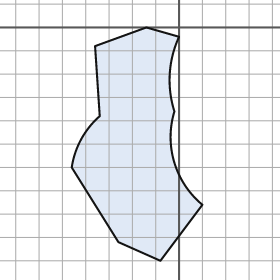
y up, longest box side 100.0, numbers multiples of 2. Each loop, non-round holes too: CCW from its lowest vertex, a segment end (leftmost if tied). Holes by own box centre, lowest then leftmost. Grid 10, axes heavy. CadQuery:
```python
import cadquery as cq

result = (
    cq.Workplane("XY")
    .moveTo(-8.0, -100.0)
    .lineTo(10.0, -76.0)
    .threePointArc((-2.0, -58.0), (-2.0, -36.0))
    .threePointArc((-4.0, -20.0), (0.0, -4.0))
    .lineTo(-14.0, 0.0)
    .lineTo(-36.0, -8.0)
    .lineTo(-34.0, -38.0)
    .threePointArc((-42.0, -48.0), (-46.0, -60.0))
    .lineTo(-26.0, -92.0)
    .close()
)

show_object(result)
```